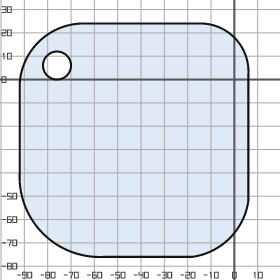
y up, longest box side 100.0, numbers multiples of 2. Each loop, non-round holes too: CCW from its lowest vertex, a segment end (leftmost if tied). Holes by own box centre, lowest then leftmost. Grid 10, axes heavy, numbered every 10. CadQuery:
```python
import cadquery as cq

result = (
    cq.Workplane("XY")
    .moveTo(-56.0, -76.0)
    .lineTo(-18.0, -76.0)
    .threePointArc((-2.0, -68.0), (6.0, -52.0))
    .lineTo(6.0, 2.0)
    .threePointArc((0.0, 18.0), (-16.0, 24.0))
    .lineTo(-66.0, 24.0)
    .threePointArc((-84.0, 16.0), (-92.0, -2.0))
    .lineTo(-92.0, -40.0)
    .threePointArc((-82.0, -66.0), (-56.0, -76.0))
    .close()
    .moveTo(-76.0, 6.0)
    .circle(6.0)
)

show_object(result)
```